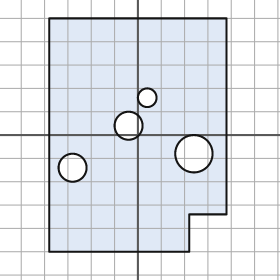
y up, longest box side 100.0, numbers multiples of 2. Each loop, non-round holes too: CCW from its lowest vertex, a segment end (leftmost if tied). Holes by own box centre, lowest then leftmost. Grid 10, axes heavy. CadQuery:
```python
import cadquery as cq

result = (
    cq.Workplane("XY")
    .moveTo(-38.0, -50.0)
    .lineTo(22.0, -50.0)
    .lineTo(22.0, -34.0)
    .lineTo(38.0, -34.0)
    .lineTo(38.0, 50.0)
    .lineTo(-38.0, 50.0)
    .close()
    .moveTo(-28.0, -14.0)
    .circle(6.0)
    .moveTo(24.0, -8.0)
    .circle(8.0)
    .moveTo(-4.0, 4.0)
    .circle(6.0)
    .moveTo(4.0, 16.0)
    .circle(4.0)
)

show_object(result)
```